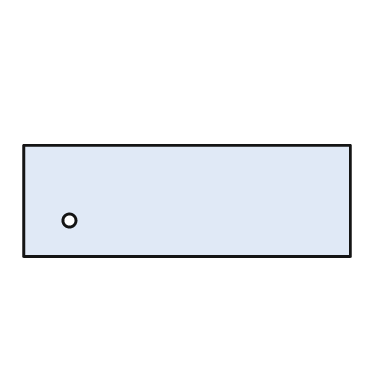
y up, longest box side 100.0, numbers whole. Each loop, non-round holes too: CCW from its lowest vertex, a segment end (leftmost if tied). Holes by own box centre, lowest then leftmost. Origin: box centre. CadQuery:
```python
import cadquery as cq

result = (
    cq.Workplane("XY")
    .moveTo(-50.0, -17.0)
    .lineTo(50.0, -17.0)
    .lineTo(50.0, 17.0)
    .lineTo(-50.0, 17.0)
    .close()
    .moveTo(-36.0, -6.0)
    .circle(2.0)
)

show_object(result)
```